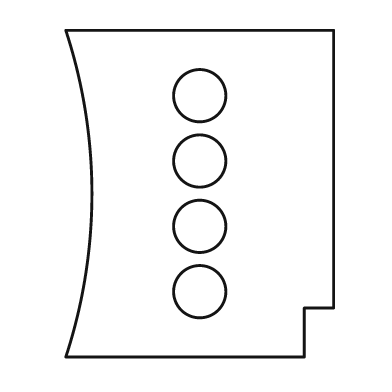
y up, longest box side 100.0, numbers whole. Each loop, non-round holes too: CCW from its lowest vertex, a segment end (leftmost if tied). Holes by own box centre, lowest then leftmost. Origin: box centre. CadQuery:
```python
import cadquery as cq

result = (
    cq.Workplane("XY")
    .moveTo(-41.0, -50.0)
    .lineTo(32.0, -50.0)
    .lineTo(32.0, -35.0)
    .lineTo(41.0, -35.0)
    .lineTo(41.0, 50.0)
    .lineTo(-41.0, 50.0)
    .threePointArc((-33.0, 0.0), (-41.0, -50.0))
    .close()
    .moveTo(0.0, -30.0)
    .circle(8.0)
    .moveTo(0.0, -10.0)
    .circle(8.0)
    .moveTo(0.0, 10.0)
    .circle(8.0)
    .moveTo(0.0, 30.0)
    .circle(8.0)
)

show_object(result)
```